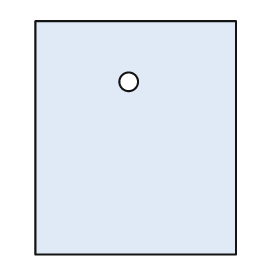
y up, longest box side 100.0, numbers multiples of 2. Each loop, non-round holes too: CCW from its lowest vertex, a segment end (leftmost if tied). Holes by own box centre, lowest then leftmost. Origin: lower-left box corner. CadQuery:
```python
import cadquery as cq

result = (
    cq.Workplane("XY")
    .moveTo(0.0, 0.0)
    .lineTo(86.0, 0.0)
    .lineTo(86.0, 100.0)
    .lineTo(0.0, 100.0)
    .close()
    .moveTo(40.0, 74.0)
    .circle(4.0)
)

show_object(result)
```